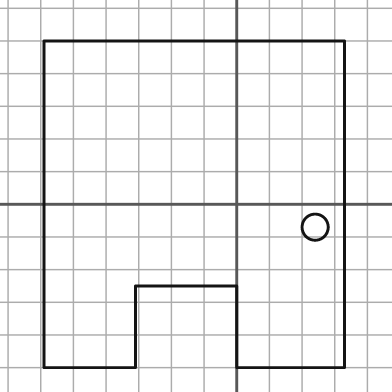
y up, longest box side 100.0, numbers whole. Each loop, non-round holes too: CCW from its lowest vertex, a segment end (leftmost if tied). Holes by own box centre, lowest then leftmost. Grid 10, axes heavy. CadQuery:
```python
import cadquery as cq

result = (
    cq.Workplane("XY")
    .moveTo(-59.0, -50.0)
    .lineTo(-31.0, -50.0)
    .lineTo(-31.0, -25.0)
    .lineTo(0.0, -25.0)
    .lineTo(0.0, -50.0)
    .lineTo(33.0, -50.0)
    .lineTo(33.0, 50.0)
    .lineTo(-59.0, 50.0)
    .close()
    .moveTo(24.0, -7.0)
    .circle(4.0)
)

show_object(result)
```